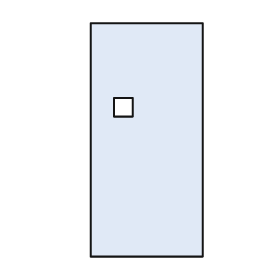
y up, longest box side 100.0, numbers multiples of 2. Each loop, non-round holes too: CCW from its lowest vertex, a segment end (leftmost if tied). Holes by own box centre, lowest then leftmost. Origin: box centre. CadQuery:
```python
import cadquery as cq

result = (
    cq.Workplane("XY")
    .moveTo(-24.0, -50.0)
    .lineTo(24.0, -50.0)
    .lineTo(24.0, 50.0)
    .lineTo(-24.0, 50.0)
    .close()
    .moveTo(-14.0, 10.0)
    .lineTo(-6.0, 10.0)
    .lineTo(-6.0, 18.0)
    .lineTo(-14.0, 18.0)
    .close()
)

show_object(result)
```